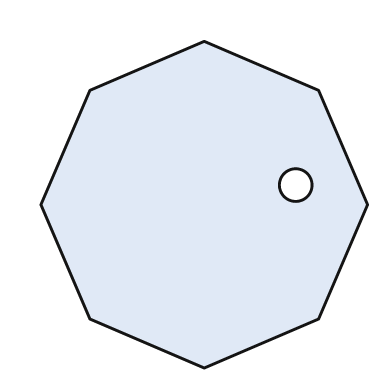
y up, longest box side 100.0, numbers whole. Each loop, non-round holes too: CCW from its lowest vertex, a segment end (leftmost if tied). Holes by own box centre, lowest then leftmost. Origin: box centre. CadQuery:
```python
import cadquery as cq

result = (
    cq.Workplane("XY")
    .moveTo(0.0, -50.0)
    .lineTo(35.0, -35.0)
    .lineTo(50.0, 0.0)
    .lineTo(35.0, 35.0)
    .lineTo(0.0, 50.0)
    .lineTo(-35.0, 35.0)
    .lineTo(-50.0, 0.0)
    .lineTo(-35.0, -35.0)
    .close()
    .moveTo(28.0, 6.0)
    .circle(5.0)
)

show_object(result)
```